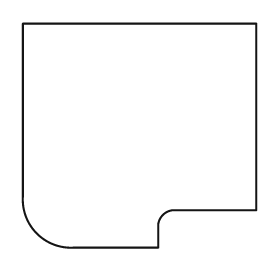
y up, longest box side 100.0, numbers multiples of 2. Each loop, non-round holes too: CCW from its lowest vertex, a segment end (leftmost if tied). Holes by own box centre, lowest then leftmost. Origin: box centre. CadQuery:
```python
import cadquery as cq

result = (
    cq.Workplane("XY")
    .moveTo(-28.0, -48.0)
    .lineTo(8.0, -48.0)
    .lineTo(8.0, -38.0)
    .threePointArc((10.0, -34.0), (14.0, -32.0))
    .lineTo(50.0, -32.0)
    .lineTo(50.0, 48.0)
    .lineTo(-50.0, 48.0)
    .lineTo(-50.0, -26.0)
    .threePointArc((-44.0, -42.0), (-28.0, -48.0))
    .close()
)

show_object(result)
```